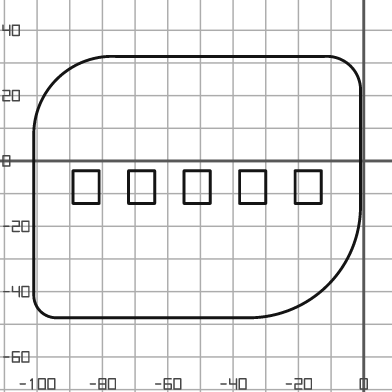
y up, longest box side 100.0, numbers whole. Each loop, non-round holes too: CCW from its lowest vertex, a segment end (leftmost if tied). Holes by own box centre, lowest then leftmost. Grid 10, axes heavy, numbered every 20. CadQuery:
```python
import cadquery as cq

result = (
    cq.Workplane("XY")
    .moveTo(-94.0, -48.0)
    .lineTo(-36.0, -48.0)
    .threePointArc((-11.0, -38.0), (-1.0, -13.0))
    .lineTo(-1.0, 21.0)
    .threePointArc((-4.0, 29.0), (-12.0, 32.0))
    .lineTo(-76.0, 32.0)
    .threePointArc((-94.0, 25.0), (-101.0, 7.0))
    .lineTo(-101.0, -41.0)
    .threePointArc((-99.0, -46.0), (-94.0, -48.0))
    .close()
    .moveTo(-89.0, -13.0)
    .lineTo(-81.0, -13.0)
    .lineTo(-81.0, -3.0)
    .lineTo(-89.0, -3.0)
    .close()
    .moveTo(-72.0, -13.0)
    .lineTo(-64.0, -13.0)
    .lineTo(-64.0, -3.0)
    .lineTo(-72.0, -3.0)
    .close()
    .moveTo(-55.0, -13.0)
    .lineTo(-47.0, -13.0)
    .lineTo(-47.0, -3.0)
    .lineTo(-55.0, -3.0)
    .close()
    .moveTo(-38.0, -13.0)
    .lineTo(-30.0, -13.0)
    .lineTo(-30.0, -3.0)
    .lineTo(-38.0, -3.0)
    .close()
    .moveTo(-21.0, -13.0)
    .lineTo(-13.0, -13.0)
    .lineTo(-13.0, -3.0)
    .lineTo(-21.0, -3.0)
    .close()
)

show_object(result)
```